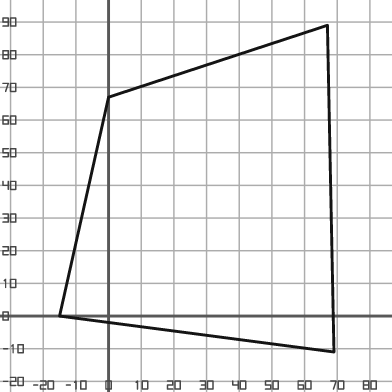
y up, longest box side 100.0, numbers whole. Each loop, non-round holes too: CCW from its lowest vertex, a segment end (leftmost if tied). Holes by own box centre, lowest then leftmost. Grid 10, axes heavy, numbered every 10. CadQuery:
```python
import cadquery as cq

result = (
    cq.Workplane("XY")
    .moveTo(69.0, -11.0)
    .lineTo(67.0, 89.0)
    .lineTo(0.0, 67.0)
    .lineTo(-15.0, 0.0)
    .close()
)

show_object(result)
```